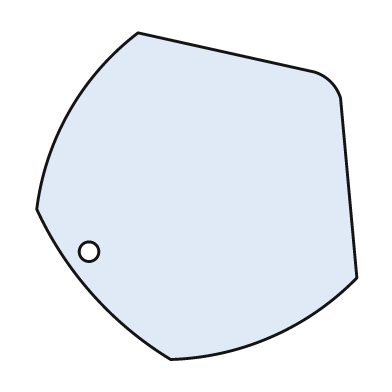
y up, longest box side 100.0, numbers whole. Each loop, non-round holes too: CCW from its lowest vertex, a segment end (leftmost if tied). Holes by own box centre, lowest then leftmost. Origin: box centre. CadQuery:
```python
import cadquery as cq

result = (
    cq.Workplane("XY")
    .moveTo(-8.0, -50.0)
    .threePointArc((23.0, -43.0), (49.0, -25.0))
    .lineTo(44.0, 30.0)
    .threePointArc((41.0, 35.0), (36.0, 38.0))
    .lineTo(-18.0, 50.0)
    .threePointArc((-39.0, 26.0), (-49.0, -4.0))
    .threePointArc((-32.0, -30.0), (-8.0, -50.0))
    .close()
    .moveTo(-33.0, -17.0)
    .circle(3.0)
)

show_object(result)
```